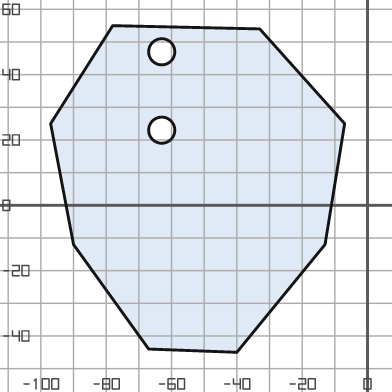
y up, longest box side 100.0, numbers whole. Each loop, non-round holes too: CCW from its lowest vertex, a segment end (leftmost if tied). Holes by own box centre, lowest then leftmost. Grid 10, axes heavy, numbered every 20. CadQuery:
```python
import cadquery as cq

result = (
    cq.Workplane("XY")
    .moveTo(-40.0, -45.0)
    .lineTo(-13.0, -12.0)
    .lineTo(-7.0, 25.0)
    .lineTo(-33.0, 54.0)
    .lineTo(-78.0, 55.0)
    .lineTo(-97.0, 25.0)
    .lineTo(-90.0, -12.0)
    .lineTo(-67.0, -44.0)
    .close()
    .moveTo(-63.0, 23.0)
    .circle(4.0)
    .moveTo(-63.0, 47.0)
    .circle(4.0)
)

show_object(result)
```